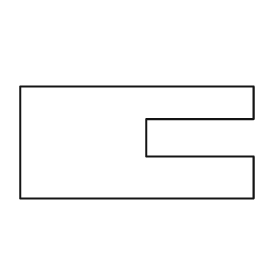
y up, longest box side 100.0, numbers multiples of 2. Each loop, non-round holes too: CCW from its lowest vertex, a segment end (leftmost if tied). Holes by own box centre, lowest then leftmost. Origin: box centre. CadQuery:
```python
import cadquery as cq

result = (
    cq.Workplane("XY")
    .moveTo(-50.0, -24.0)
    .lineTo(50.0, -24.0)
    .lineTo(50.0, -6.0)
    .lineTo(4.0, -6.0)
    .lineTo(4.0, 10.0)
    .lineTo(50.0, 10.0)
    .lineTo(50.0, 24.0)
    .lineTo(-50.0, 24.0)
    .close()
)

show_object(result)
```